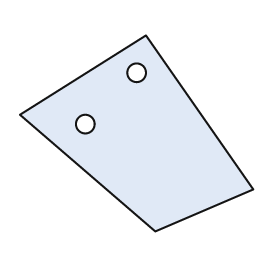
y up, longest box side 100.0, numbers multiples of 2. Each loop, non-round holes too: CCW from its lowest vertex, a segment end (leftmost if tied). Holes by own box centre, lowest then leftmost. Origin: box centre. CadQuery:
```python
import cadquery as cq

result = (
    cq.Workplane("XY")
    .moveTo(8.0, -42.0)
    .lineTo(50.0, -24.0)
    .lineTo(4.0, 42.0)
    .lineTo(-50.0, 8.0)
    .close()
    .moveTo(-22.0, 4.0)
    .circle(4.0)
    .moveTo(0.0, 26.0)
    .circle(4.0)
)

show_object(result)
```